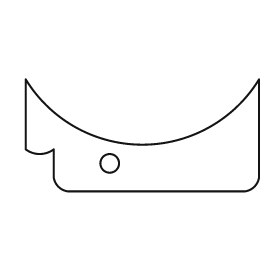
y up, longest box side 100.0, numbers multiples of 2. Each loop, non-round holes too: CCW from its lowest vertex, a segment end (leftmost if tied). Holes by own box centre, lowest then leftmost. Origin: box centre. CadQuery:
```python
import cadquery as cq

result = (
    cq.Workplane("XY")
    .moveTo(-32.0, -24.0)
    .lineTo(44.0, -24.0)
    .threePointArc((48.0, -22.0), (50.0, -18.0))
    .lineTo(50.0, 24.0)
    .threePointArc((0.0, -4.0), (-50.0, 24.0))
    .lineTo(-50.0, -6.0)
    .threePointArc((-44.0, -8.0), (-38.0, -6.0))
    .lineTo(-38.0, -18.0)
    .threePointArc((-36.0, -22.0), (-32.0, -24.0))
    .close()
    .moveTo(-14.0, -12.0)
    .circle(4.0)
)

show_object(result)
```